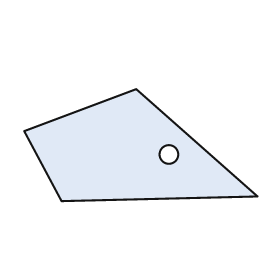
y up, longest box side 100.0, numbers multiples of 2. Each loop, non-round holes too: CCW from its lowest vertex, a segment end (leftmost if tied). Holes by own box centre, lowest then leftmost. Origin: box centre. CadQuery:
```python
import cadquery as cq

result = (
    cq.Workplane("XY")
    .moveTo(-34.0, -24.0)
    .lineTo(50.0, -22.0)
    .lineTo(-2.0, 24.0)
    .lineTo(-50.0, 6.0)
    .close()
    .moveTo(12.0, -4.0)
    .circle(4.0)
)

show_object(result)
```